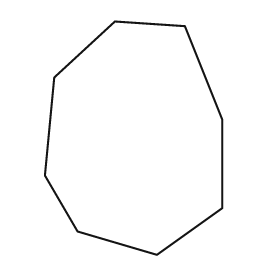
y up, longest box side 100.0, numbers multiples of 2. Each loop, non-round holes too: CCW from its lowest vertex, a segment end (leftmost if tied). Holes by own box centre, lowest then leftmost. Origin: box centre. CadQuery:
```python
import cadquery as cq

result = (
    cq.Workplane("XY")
    .moveTo(10.0, -50.0)
    .lineTo(38.0, -30.0)
    .lineTo(38.0, 8.0)
    .lineTo(22.0, 48.0)
    .lineTo(-8.0, 50.0)
    .lineTo(-34.0, 26.0)
    .lineTo(-38.0, -16.0)
    .lineTo(-24.0, -40.0)
    .close()
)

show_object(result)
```